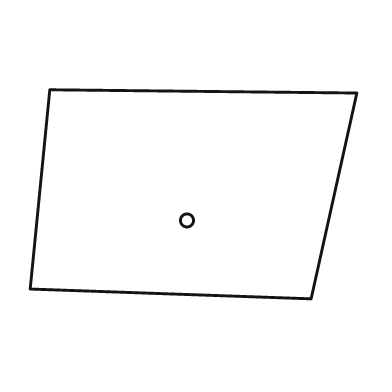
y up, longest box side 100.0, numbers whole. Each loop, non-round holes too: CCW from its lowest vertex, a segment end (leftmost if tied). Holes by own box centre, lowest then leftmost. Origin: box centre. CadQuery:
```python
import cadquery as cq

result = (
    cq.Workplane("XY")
    .moveTo(36.0, -32.0)
    .lineTo(50.0, 31.0)
    .lineTo(-44.0, 32.0)
    .lineTo(-50.0, -29.0)
    .close()
    .moveTo(-2.0, -8.0)
    .circle(2.0)
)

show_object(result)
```